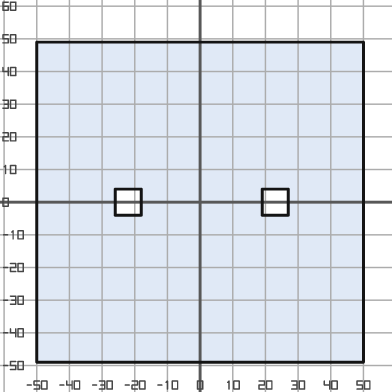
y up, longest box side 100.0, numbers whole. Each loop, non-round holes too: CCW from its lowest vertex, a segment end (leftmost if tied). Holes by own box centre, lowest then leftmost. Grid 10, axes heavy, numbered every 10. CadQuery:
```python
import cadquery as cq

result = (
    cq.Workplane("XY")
    .moveTo(-50.0, -49.0)
    .lineTo(50.0, -49.0)
    .lineTo(50.0, 49.0)
    .lineTo(-50.0, 49.0)
    .close()
    .moveTo(-26.0, -4.0)
    .lineTo(-18.0, -4.0)
    .lineTo(-18.0, 4.0)
    .lineTo(-26.0, 4.0)
    .close()
    .moveTo(19.0, -4.0)
    .lineTo(27.0, -4.0)
    .lineTo(27.0, 4.0)
    .lineTo(19.0, 4.0)
    .close()
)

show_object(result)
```